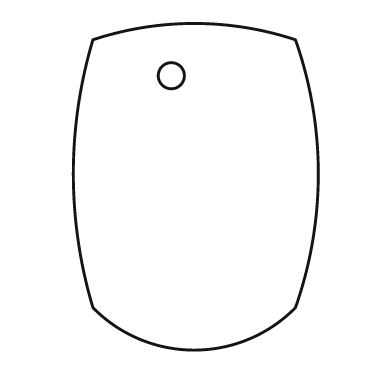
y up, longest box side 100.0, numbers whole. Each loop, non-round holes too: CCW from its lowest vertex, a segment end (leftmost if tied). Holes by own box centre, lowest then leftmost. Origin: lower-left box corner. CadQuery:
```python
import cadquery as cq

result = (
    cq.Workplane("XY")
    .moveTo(6.0, 13.0)
    .threePointArc((37.0, 0.0), (68.0, 13.0))
    .threePointArc((75.0, 54.0), (68.0, 95.0))
    .threePointArc((37.0, 100.0), (6.0, 95.0))
    .threePointArc((0.0, 54.0), (6.0, 13.0))
    .close()
    .moveTo(30.0, 84.0)
    .circle(4.0)
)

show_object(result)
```